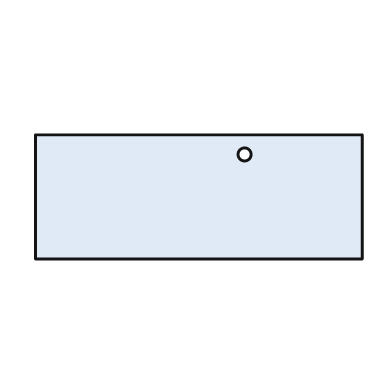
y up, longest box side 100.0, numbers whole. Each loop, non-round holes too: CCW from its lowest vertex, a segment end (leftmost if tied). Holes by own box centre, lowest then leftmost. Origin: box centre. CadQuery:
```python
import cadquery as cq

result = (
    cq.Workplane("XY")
    .moveTo(-50.0, -19.0)
    .lineTo(50.0, -19.0)
    .lineTo(50.0, 19.0)
    .lineTo(-50.0, 19.0)
    .close()
    .moveTo(14.0, 13.0)
    .circle(2.0)
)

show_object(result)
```